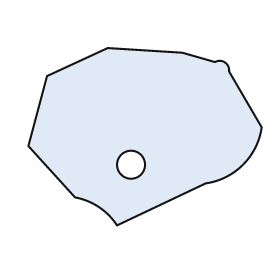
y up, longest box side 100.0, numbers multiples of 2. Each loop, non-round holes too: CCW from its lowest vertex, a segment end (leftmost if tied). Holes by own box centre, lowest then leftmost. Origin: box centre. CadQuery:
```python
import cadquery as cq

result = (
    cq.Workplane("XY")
    .moveTo(-12.0, -38.0)
    .lineTo(26.0, -20.0)
    .threePointArc((42.0, -12.0), (50.0, 4.0))
    .lineTo(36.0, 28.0)
    .threePointArc((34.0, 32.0), (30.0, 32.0))
    .lineTo(16.0, 36.0)
    .lineTo(-16.0, 38.0)
    .lineTo(-42.0, 26.0)
    .lineTo(-50.0, -4.0)
    .lineTo(-30.0, -26.0)
    .threePointArc((-20.0, -30.0), (-12.0, -38.0))
    .close()
    .moveTo(-6.0, -12.0)
    .circle(6.0)
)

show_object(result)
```